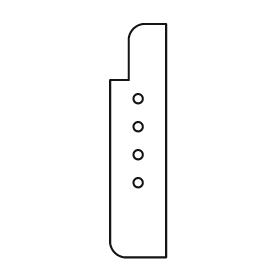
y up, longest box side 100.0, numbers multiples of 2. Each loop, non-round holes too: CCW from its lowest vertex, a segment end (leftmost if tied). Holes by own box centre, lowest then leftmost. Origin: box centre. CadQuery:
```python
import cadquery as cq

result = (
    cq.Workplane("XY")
    .moveTo(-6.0, -50.0)
    .lineTo(12.0, -50.0)
    .lineTo(12.0, 50.0)
    .lineTo(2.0, 50.0)
    .threePointArc((-2.0, 48.0), (-4.0, 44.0))
    .lineTo(-4.0, 26.0)
    .lineTo(-12.0, 26.0)
    .lineTo(-12.0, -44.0)
    .threePointArc((-10.0, -48.0), (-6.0, -50.0))
    .close()
    .moveTo(0.0, -18.0)
    .circle(2.0)
    .moveTo(0.0, -6.0)
    .circle(2.0)
    .moveTo(0.0, 6.0)
    .circle(2.0)
    .moveTo(0.0, 18.0)
    .circle(2.0)
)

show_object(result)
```